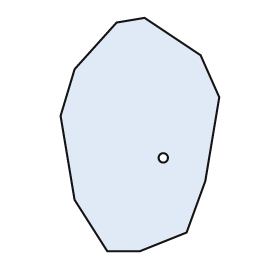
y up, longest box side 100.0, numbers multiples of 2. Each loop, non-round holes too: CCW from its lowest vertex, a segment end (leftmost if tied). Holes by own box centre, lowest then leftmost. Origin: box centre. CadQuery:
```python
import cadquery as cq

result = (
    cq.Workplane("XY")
    .moveTo(-14.0, -50.0)
    .lineTo(0.0, -50.0)
    .lineTo(20.0, -42.0)
    .lineTo(28.0, -20.0)
    .lineTo(34.0, 16.0)
    .lineTo(26.0, 34.0)
    .lineTo(2.0, 50.0)
    .lineTo(-10.0, 48.0)
    .lineTo(-28.0, 28.0)
    .lineTo(-34.0, 8.0)
    .lineTo(-28.0, -28.0)
    .close()
    .moveTo(10.0, -10.0)
    .circle(2.0)
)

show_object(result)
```